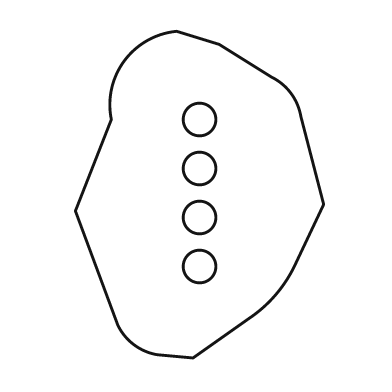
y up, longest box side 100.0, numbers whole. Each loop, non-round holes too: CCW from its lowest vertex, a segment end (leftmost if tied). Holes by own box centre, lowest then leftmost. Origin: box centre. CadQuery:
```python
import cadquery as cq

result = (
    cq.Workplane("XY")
    .moveTo(-2.0, -50.0)
    .lineTo(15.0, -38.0)
    .threePointArc((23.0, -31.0), (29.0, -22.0))
    .lineTo(38.0, -3.0)
    .lineTo(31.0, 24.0)
    .threePointArc((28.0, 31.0), (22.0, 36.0))
    .lineTo(6.0, 46.0)
    .lineTo(-7.0, 50.0)
    .threePointArc((-23.0, 41.0), (-27.0, 23.0))
    .lineTo(-38.0, -5.0)
    .lineTo(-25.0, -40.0)
    .threePointArc((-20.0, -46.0), (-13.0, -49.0))
    .close()
    .moveTo(0.0, -22.0)
    .circle(5.0)
    .moveTo(0.0, -7.0)
    .circle(5.0)
    .moveTo(0.0, 8.0)
    .circle(5.0)
    .moveTo(0.0, 23.0)
    .circle(5.0)
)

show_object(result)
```